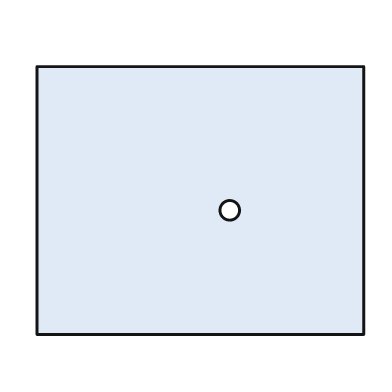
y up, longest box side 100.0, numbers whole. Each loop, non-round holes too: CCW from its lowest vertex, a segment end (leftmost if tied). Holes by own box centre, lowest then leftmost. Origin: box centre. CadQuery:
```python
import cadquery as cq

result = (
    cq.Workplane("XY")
    .moveTo(-50.0, -41.0)
    .lineTo(50.0, -41.0)
    .lineTo(50.0, 41.0)
    .lineTo(-50.0, 41.0)
    .close()
    .moveTo(9.0, -3.0)
    .circle(3.0)
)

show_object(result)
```